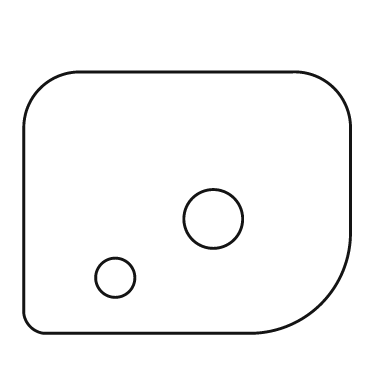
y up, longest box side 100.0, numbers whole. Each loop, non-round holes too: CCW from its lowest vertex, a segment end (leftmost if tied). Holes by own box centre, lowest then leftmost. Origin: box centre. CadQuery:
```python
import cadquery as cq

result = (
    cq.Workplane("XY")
    .moveTo(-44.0, -40.0)
    .lineTo(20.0, -40.0)
    .threePointArc((41.0, -31.0), (50.0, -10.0))
    .lineTo(50.0, 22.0)
    .threePointArc((45.0, 35.0), (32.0, 40.0))
    .lineTo(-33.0, 40.0)
    .threePointArc((-45.0, 35.0), (-50.0, 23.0))
    .lineTo(-50.0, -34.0)
    .threePointArc((-48.0, -38.0), (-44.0, -40.0))
    .close()
    .moveTo(-22.0, -23.0)
    .circle(6.0)
    .moveTo(8.0, -5.0)
    .circle(9.0)
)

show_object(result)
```